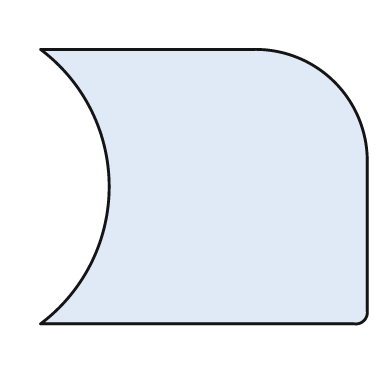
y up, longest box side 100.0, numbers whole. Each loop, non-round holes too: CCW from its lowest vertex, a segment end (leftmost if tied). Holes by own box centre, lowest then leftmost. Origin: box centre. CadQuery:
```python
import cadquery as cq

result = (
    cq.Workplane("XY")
    .moveTo(-50.0, -42.0)
    .lineTo(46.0, -42.0)
    .threePointArc((49.0, -41.0), (50.0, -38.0))
    .lineTo(50.0, 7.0)
    .threePointArc((40.0, 32.0), (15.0, 42.0))
    .lineTo(-50.0, 42.0)
    .threePointArc((-29.0, 0.0), (-50.0, -42.0))
    .close()
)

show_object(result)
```